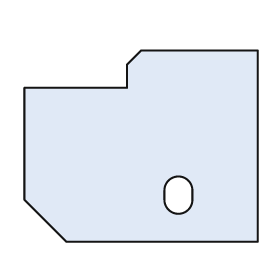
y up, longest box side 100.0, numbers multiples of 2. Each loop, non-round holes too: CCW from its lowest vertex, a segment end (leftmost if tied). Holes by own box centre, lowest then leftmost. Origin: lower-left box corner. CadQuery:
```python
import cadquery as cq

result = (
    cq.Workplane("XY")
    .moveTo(18.0, 0.0)
    .lineTo(100.0, 0.0)
    .lineTo(100.0, 82.0)
    .lineTo(50.0, 82.0)
    .lineTo(44.0, 76.0)
    .lineTo(44.0, 66.0)
    .lineTo(0.0, 66.0)
    .lineTo(0.0, 18.0)
    .close()
    .moveTo(60.0, 18.0)
    .threePointArc((66.0, 12.0), (72.0, 18.0))
    .lineTo(72.0, 22.0)
    .threePointArc((66.0, 28.0), (60.0, 22.0))
    .close()
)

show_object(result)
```